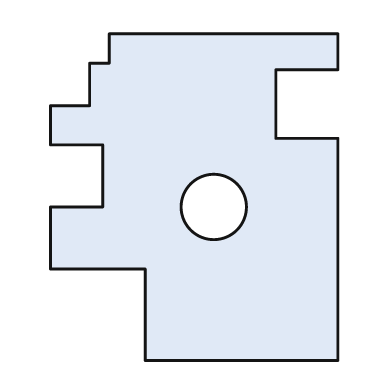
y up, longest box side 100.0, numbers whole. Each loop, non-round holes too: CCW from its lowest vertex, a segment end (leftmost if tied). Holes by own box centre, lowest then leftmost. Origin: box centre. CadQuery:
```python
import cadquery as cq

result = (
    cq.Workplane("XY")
    .moveTo(-15.0, -50.0)
    .lineTo(44.0, -50.0)
    .lineTo(44.0, 18.0)
    .lineTo(25.0, 18.0)
    .lineTo(25.0, 39.0)
    .lineTo(44.0, 39.0)
    .lineTo(44.0, 50.0)
    .lineTo(-26.0, 50.0)
    .lineTo(-26.0, 41.0)
    .lineTo(-32.0, 41.0)
    .lineTo(-32.0, 28.0)
    .lineTo(-44.0, 28.0)
    .lineTo(-44.0, 16.0)
    .lineTo(-28.0, 16.0)
    .lineTo(-28.0, -3.0)
    .lineTo(-44.0, -3.0)
    .lineTo(-44.0, -22.0)
    .lineTo(-15.0, -22.0)
    .close()
    .moveTo(6.0, -3.0)
    .circle(10.0)
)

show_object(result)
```